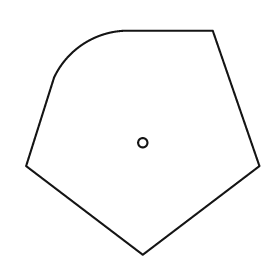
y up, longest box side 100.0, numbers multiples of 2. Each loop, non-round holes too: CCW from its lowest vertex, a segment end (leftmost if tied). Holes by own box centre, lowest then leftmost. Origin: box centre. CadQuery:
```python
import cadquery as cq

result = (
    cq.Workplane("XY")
    .moveTo(0.0, -48.0)
    .lineTo(50.0, -10.0)
    .lineTo(30.0, 48.0)
    .lineTo(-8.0, 48.0)
    .threePointArc((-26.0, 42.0), (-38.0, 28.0))
    .lineTo(-50.0, -10.0)
    .close()
    .moveTo(0.0, 0.0)
    .circle(2.0)
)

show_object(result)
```